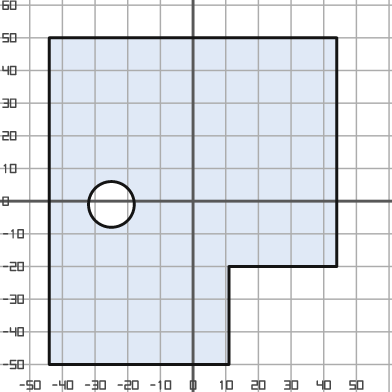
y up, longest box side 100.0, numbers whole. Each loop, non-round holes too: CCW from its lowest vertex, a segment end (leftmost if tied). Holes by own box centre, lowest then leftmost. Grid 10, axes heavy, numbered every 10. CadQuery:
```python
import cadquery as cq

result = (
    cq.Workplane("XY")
    .moveTo(-44.0, -50.0)
    .lineTo(11.0, -50.0)
    .lineTo(11.0, -20.0)
    .lineTo(44.0, -20.0)
    .lineTo(44.0, 50.0)
    .lineTo(-44.0, 50.0)
    .close()
    .moveTo(-25.0, -1.0)
    .circle(7.0)
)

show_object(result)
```